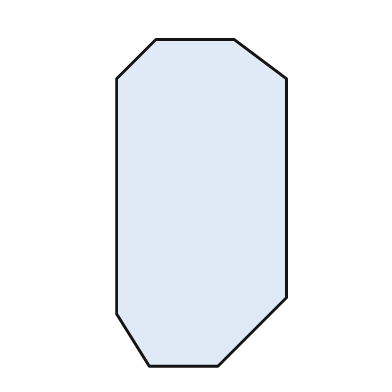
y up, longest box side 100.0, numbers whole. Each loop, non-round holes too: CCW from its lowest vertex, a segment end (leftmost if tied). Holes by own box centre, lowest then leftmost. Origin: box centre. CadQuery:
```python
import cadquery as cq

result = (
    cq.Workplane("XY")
    .moveTo(-16.0, -50.0)
    .lineTo(5.0, -50.0)
    .lineTo(26.0, -29.0)
    .lineTo(26.0, 38.0)
    .lineTo(10.0, 50.0)
    .lineTo(-14.0, 50.0)
    .lineTo(-26.0, 38.0)
    .lineTo(-26.0, -34.0)
    .close()
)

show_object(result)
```